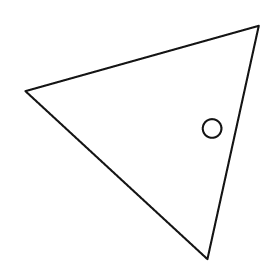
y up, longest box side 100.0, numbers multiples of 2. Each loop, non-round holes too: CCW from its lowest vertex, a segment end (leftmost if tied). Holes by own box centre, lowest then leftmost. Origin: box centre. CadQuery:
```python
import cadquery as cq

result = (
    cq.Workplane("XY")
    .moveTo(28.0, -50.0)
    .lineTo(50.0, 50.0)
    .lineTo(-50.0, 22.0)
    .close()
    .moveTo(30.0, 6.0)
    .circle(4.0)
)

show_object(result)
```